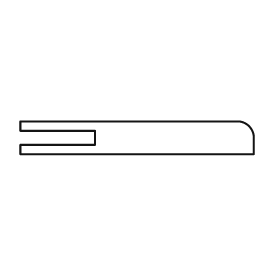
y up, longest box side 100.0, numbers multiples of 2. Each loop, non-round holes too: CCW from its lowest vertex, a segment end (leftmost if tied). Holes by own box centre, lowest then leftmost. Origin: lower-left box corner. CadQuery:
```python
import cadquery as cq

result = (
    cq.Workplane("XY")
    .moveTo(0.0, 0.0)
    .lineTo(100.0, 0.0)
    .lineTo(100.0, 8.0)
    .threePointArc((98.0, 12.0), (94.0, 14.0))
    .lineTo(0.0, 14.0)
    .lineTo(0.0, 10.0)
    .lineTo(32.0, 10.0)
    .lineTo(32.0, 4.0)
    .lineTo(0.0, 4.0)
    .close()
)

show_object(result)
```